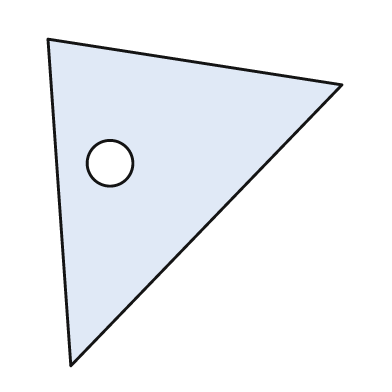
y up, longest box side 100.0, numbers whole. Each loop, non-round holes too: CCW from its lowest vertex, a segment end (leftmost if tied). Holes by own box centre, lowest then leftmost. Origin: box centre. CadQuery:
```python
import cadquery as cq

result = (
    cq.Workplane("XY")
    .moveTo(-38.0, -50.0)
    .lineTo(45.0, 36.0)
    .lineTo(-45.0, 50.0)
    .close()
    .moveTo(-26.0, 12.0)
    .circle(7.0)
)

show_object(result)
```